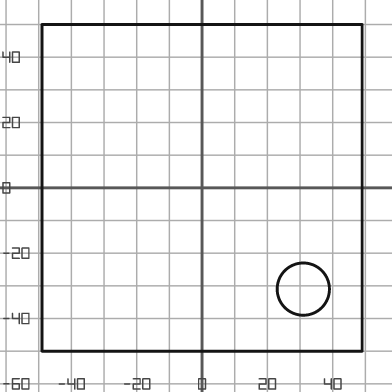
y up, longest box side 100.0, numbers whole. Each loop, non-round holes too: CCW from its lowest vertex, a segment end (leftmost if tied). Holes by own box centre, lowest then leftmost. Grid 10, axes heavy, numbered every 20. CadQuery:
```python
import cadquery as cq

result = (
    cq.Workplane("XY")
    .moveTo(-49.0, -50.0)
    .lineTo(49.0, -50.0)
    .lineTo(49.0, 50.0)
    .lineTo(-49.0, 50.0)
    .close()
    .moveTo(31.0, -31.0)
    .circle(8.0)
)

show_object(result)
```